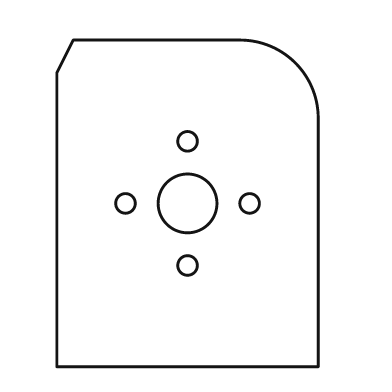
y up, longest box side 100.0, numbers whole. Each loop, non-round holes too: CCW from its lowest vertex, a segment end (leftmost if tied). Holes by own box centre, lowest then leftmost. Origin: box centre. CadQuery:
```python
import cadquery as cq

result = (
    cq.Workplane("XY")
    .moveTo(-40.0, -50.0)
    .lineTo(40.0, -50.0)
    .lineTo(40.0, 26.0)
    .threePointArc((33.0, 43.0), (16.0, 50.0))
    .lineTo(-35.0, 50.0)
    .lineTo(-40.0, 40.0)
    .close()
    .moveTo(0.0, -19.0)
    .circle(3.0)
    .moveTo(-19.0, 0.0)
    .circle(3.0)
    .moveTo(0.0, 0.0)
    .circle(9.0)
    .moveTo(19.0, 0.0)
    .circle(3.0)
    .moveTo(0.0, 19.0)
    .circle(3.0)
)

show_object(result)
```